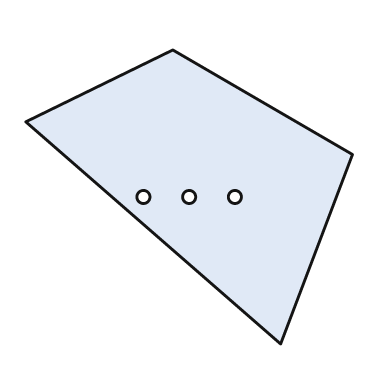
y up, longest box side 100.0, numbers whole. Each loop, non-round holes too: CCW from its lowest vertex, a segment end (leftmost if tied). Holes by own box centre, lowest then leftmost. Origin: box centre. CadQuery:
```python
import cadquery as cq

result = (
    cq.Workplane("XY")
    .moveTo(28.0, -45.0)
    .lineTo(50.0, 13.0)
    .lineTo(-5.0, 45.0)
    .lineTo(-50.0, 23.0)
    .close()
    .moveTo(-14.0, 0.0)
    .circle(2.0)
    .moveTo(0.0, 0.0)
    .circle(2.0)
    .moveTo(14.0, 0.0)
    .circle(2.0)
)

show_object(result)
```